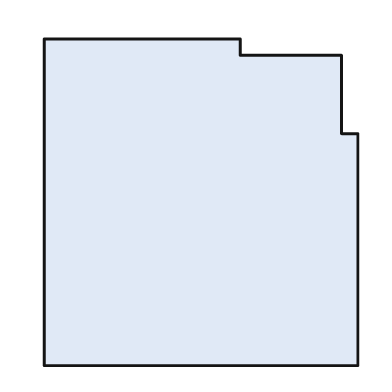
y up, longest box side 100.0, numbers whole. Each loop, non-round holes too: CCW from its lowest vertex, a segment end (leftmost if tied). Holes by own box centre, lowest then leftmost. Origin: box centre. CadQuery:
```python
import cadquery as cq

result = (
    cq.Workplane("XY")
    .moveTo(-48.0, -50.0)
    .lineTo(48.0, -50.0)
    .lineTo(48.0, 21.0)
    .lineTo(43.0, 21.0)
    .lineTo(43.0, 45.0)
    .lineTo(12.0, 45.0)
    .lineTo(12.0, 50.0)
    .lineTo(-48.0, 50.0)
    .close()
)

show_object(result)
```